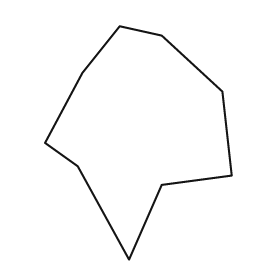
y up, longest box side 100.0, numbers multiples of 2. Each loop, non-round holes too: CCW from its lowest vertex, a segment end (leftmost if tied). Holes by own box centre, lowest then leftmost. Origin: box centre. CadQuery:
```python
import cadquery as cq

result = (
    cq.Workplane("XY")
    .moveTo(-4.0, -50.0)
    .lineTo(10.0, -18.0)
    .lineTo(40.0, -14.0)
    .lineTo(36.0, 22.0)
    .lineTo(10.0, 46.0)
    .lineTo(-8.0, 50.0)
    .lineTo(-24.0, 30.0)
    .lineTo(-40.0, 0.0)
    .lineTo(-26.0, -10.0)
    .close()
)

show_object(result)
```